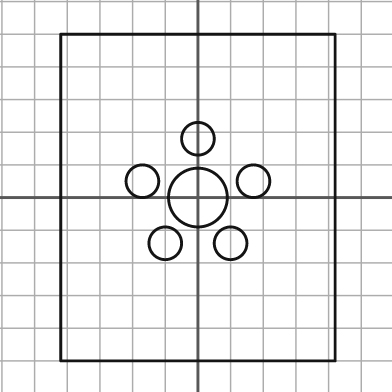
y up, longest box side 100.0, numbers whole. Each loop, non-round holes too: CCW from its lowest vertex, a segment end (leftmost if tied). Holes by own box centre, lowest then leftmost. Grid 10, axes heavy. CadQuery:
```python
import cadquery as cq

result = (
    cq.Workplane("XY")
    .moveTo(-42.0, -50.0)
    .lineTo(42.0, -50.0)
    .lineTo(42.0, 50.0)
    .lineTo(-42.0, 50.0)
    .close()
    .moveTo(-10.0, -14.0)
    .circle(5.0)
    .moveTo(10.0, -14.0)
    .circle(5.0)
    .moveTo(0.0, 0.0)
    .circle(9.0)
    .moveTo(-17.0, 5.0)
    .circle(5.0)
    .moveTo(17.0, 5.0)
    .circle(5.0)
    .moveTo(0.0, 18.0)
    .circle(5.0)
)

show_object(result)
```